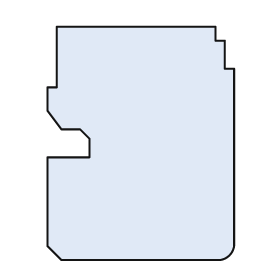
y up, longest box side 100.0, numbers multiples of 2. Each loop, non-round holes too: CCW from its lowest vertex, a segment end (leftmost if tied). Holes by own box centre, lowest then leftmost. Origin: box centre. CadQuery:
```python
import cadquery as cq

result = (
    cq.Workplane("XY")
    .moveTo(-34.0, -50.0)
    .lineTo(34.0, -50.0)
    .threePointArc((38.0, -48.0), (40.0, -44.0))
    .lineTo(40.0, 32.0)
    .lineTo(36.0, 32.0)
    .lineTo(36.0, 44.0)
    .lineTo(32.0, 44.0)
    .lineTo(32.0, 50.0)
    .lineTo(-36.0, 50.0)
    .lineTo(-36.0, 24.0)
    .lineTo(-40.0, 24.0)
    .lineTo(-40.0, 14.0)
    .lineTo(-34.0, 6.0)
    .lineTo(-26.0, 6.0)
    .lineTo(-22.0, 2.0)
    .lineTo(-22.0, -6.0)
    .lineTo(-40.0, -6.0)
    .lineTo(-40.0, -44.0)
    .close()
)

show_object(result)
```